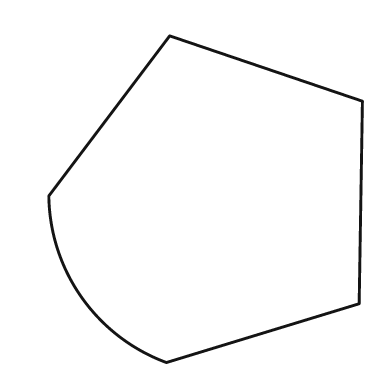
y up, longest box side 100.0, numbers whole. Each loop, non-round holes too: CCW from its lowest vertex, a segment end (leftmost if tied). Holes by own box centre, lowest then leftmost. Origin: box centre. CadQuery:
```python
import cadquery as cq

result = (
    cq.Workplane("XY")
    .moveTo(-12.0, -50.0)
    .lineTo(47.0, -32.0)
    .lineTo(48.0, 30.0)
    .lineTo(-11.0, 50.0)
    .lineTo(-48.0, 1.0)
    .threePointArc((-38.0, -30.0), (-12.0, -50.0))
    .close()
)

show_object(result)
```